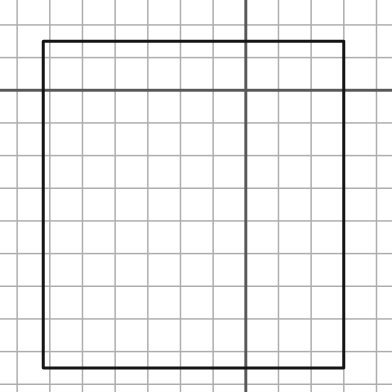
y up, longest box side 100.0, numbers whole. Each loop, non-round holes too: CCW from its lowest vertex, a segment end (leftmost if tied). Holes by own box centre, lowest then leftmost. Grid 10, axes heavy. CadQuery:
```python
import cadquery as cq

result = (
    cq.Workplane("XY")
    .moveTo(-62.0, -85.0)
    .lineTo(30.0, -85.0)
    .lineTo(30.0, 15.0)
    .lineTo(-62.0, 15.0)
    .close()
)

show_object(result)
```